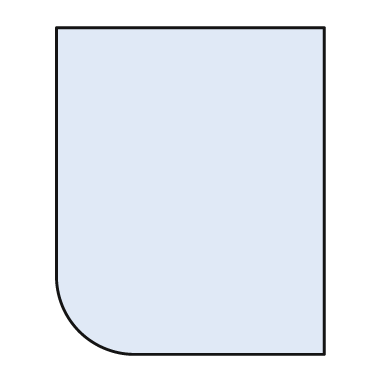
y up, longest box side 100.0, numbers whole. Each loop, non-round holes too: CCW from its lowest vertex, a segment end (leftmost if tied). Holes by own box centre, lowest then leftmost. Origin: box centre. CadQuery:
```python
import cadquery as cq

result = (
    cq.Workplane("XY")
    .moveTo(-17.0, -50.0)
    .lineTo(41.0, -50.0)
    .lineTo(41.0, 50.0)
    .lineTo(-41.0, 50.0)
    .lineTo(-41.0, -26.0)
    .threePointArc((-34.0, -43.0), (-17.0, -50.0))
    .close()
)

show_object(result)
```